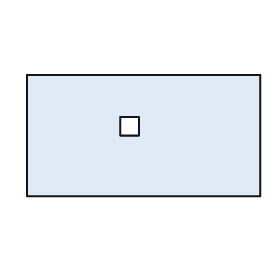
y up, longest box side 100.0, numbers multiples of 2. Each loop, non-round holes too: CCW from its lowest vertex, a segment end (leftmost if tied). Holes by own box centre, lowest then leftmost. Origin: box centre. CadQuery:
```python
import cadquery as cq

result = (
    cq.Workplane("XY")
    .moveTo(-50.0, -26.0)
    .lineTo(50.0, -26.0)
    .lineTo(50.0, 26.0)
    .lineTo(-50.0, 26.0)
    .close()
    .moveTo(-10.0, 0.0)
    .lineTo(-2.0, 0.0)
    .lineTo(-2.0, 8.0)
    .lineTo(-10.0, 8.0)
    .close()
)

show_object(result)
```